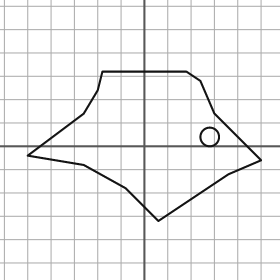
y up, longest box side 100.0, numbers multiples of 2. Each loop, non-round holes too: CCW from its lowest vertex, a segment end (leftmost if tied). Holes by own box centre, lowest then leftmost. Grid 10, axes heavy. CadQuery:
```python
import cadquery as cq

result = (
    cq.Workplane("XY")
    .moveTo(6.0, -32.0)
    .lineTo(36.0, -12.0)
    .lineTo(50.0, -6.0)
    .lineTo(30.0, 14.0)
    .lineTo(24.0, 28.0)
    .lineTo(18.0, 32.0)
    .lineTo(-18.0, 32.0)
    .lineTo(-20.0, 24.0)
    .lineTo(-26.0, 14.0)
    .lineTo(-50.0, -4.0)
    .lineTo(-26.0, -8.0)
    .lineTo(-8.0, -18.0)
    .close()
    .moveTo(28.0, 4.0)
    .circle(4.0)
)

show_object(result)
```